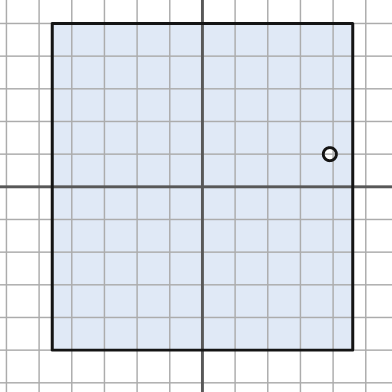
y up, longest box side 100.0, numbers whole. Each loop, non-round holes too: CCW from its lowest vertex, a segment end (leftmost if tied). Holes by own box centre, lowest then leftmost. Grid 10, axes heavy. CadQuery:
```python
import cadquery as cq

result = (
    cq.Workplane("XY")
    .moveTo(-46.0, -50.0)
    .lineTo(46.0, -50.0)
    .lineTo(46.0, 50.0)
    .lineTo(-46.0, 50.0)
    .close()
    .moveTo(39.0, 10.0)
    .circle(2.0)
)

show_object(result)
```